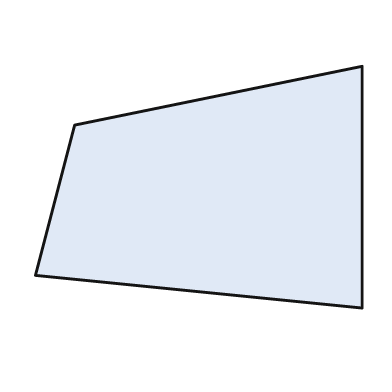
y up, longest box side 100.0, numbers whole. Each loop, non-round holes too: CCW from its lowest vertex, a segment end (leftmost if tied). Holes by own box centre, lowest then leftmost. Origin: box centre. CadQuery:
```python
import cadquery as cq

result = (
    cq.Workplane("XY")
    .moveTo(50.0, -37.0)
    .lineTo(50.0, 37.0)
    .lineTo(-38.0, 19.0)
    .lineTo(-50.0, -27.0)
    .close()
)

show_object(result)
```